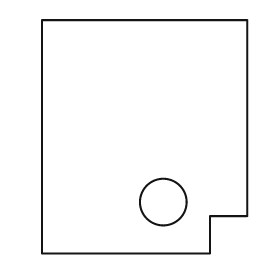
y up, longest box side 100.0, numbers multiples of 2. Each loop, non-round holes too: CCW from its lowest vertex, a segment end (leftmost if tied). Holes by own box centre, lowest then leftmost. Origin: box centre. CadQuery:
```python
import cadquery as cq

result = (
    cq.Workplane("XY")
    .moveTo(-44.0, -50.0)
    .lineTo(28.0, -50.0)
    .lineTo(28.0, -34.0)
    .lineTo(44.0, -34.0)
    .lineTo(44.0, 50.0)
    .lineTo(-44.0, 50.0)
    .close()
    .moveTo(8.0, -28.0)
    .circle(10.0)
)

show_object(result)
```